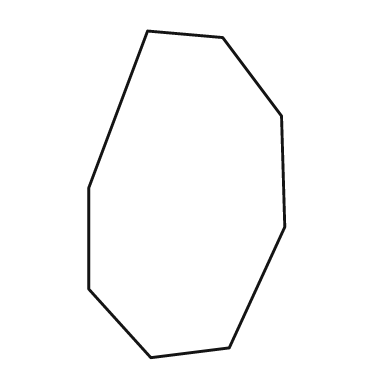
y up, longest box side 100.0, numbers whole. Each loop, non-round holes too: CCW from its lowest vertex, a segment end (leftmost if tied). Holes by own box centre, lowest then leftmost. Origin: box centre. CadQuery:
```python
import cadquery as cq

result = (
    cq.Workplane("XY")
    .moveTo(-11.0, -50.0)
    .lineTo(13.0, -47.0)
    .lineTo(30.0, -10.0)
    .lineTo(29.0, 24.0)
    .lineTo(11.0, 48.0)
    .lineTo(-12.0, 50.0)
    .lineTo(-30.0, 2.0)
    .lineTo(-30.0, -29.0)
    .close()
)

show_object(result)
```